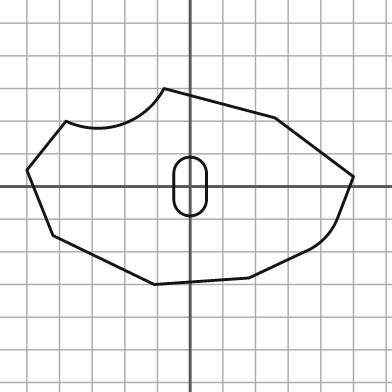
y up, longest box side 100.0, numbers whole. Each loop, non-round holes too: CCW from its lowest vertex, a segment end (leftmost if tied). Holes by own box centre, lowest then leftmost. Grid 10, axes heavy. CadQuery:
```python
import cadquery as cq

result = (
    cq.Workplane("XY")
    .moveTo(-11.0, -30.0)
    .lineTo(18.0, -28.0)
    .lineTo(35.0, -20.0)
    .threePointArc((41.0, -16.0), (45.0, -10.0))
    .lineTo(50.0, 3.0)
    .lineTo(26.0, 21.0)
    .lineTo(-8.0, 30.0)
    .threePointArc((-21.0, 19.0), (-38.0, 20.0))
    .lineTo(-50.0, 5.0)
    .lineTo(-42.0, -15.0)
    .close()
    .moveTo(-5.0, -4.0)
    .threePointArc((0.0, -9.0), (5.0, -4.0))
    .lineTo(5.0, 4.0)
    .threePointArc((0.0, 9.0), (-5.0, 4.0))
    .close()
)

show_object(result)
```